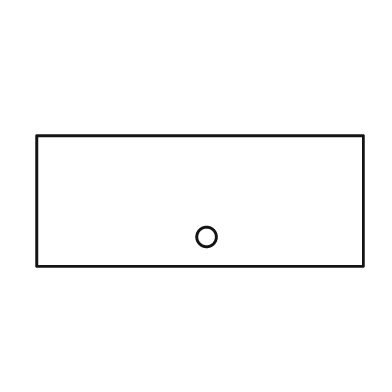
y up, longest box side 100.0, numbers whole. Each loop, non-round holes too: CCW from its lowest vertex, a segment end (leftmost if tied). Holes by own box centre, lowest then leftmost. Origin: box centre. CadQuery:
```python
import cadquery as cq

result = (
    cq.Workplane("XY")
    .moveTo(-50.0, -20.0)
    .lineTo(50.0, -20.0)
    .lineTo(50.0, 20.0)
    .lineTo(-50.0, 20.0)
    .close()
    .moveTo(2.0, -11.0)
    .circle(3.0)
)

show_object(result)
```